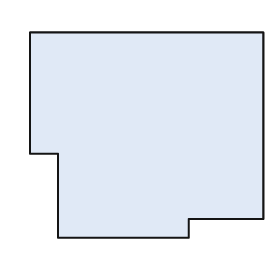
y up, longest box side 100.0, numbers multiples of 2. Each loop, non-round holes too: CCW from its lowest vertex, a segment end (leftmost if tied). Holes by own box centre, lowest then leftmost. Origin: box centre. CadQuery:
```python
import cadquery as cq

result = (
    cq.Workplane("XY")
    .moveTo(-38.0, -44.0)
    .lineTo(18.0, -44.0)
    .lineTo(18.0, -36.0)
    .lineTo(50.0, -36.0)
    .lineTo(50.0, 44.0)
    .lineTo(-50.0, 44.0)
    .lineTo(-50.0, -8.0)
    .lineTo(-38.0, -8.0)
    .close()
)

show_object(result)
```